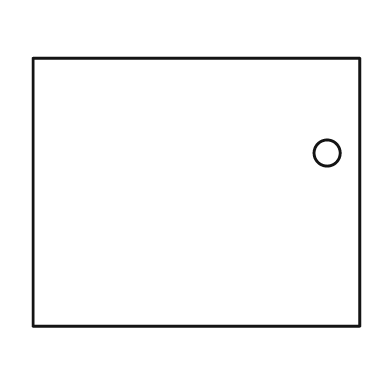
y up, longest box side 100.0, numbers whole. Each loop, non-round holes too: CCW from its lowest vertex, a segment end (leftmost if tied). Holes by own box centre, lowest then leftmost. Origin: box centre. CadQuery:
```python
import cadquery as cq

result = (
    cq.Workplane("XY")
    .moveTo(-50.0, -41.0)
    .lineTo(50.0, -41.0)
    .lineTo(50.0, 41.0)
    .lineTo(-50.0, 41.0)
    .close()
    .moveTo(40.0, 12.0)
    .circle(4.0)
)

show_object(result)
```